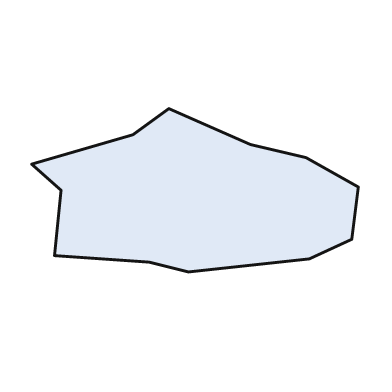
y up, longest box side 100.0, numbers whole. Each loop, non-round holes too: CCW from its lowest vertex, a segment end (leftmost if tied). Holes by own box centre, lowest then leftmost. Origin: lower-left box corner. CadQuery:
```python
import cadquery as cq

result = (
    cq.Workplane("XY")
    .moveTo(48.0, 0.0)
    .lineTo(85.0, 4.0)
    .lineTo(98.0, 10.0)
    .lineTo(100.0, 26.0)
    .lineTo(84.0, 35.0)
    .lineTo(67.0, 39.0)
    .lineTo(42.0, 50.0)
    .lineTo(31.0, 42.0)
    .lineTo(0.0, 33.0)
    .lineTo(9.0, 25.0)
    .lineTo(7.0, 5.0)
    .lineTo(36.0, 3.0)
    .close()
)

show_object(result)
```